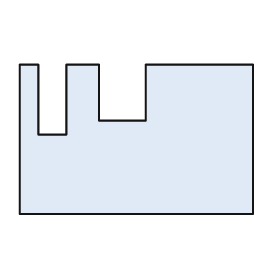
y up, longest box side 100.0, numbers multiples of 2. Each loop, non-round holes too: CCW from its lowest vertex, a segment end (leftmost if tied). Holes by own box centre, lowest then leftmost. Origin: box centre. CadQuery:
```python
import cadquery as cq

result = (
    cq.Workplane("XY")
    .moveTo(-50.0, -32.0)
    .lineTo(50.0, -32.0)
    .lineTo(50.0, 32.0)
    .lineTo(4.0, 32.0)
    .lineTo(4.0, 8.0)
    .lineTo(-16.0, 8.0)
    .lineTo(-16.0, 32.0)
    .lineTo(-30.0, 32.0)
    .lineTo(-30.0, 2.0)
    .lineTo(-42.0, 2.0)
    .lineTo(-42.0, 32.0)
    .lineTo(-50.0, 32.0)
    .close()
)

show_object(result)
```